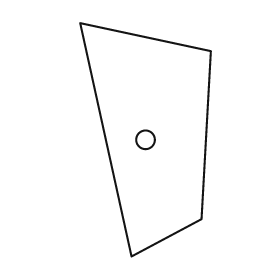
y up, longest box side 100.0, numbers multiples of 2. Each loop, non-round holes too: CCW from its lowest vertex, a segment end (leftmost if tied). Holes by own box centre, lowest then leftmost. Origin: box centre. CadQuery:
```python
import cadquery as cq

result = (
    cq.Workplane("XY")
    .moveTo(-6.0, -50.0)
    .lineTo(24.0, -34.0)
    .lineTo(28.0, 38.0)
    .lineTo(-28.0, 50.0)
    .close()
    .moveTo(0.0, 0.0)
    .circle(4.0)
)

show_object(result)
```